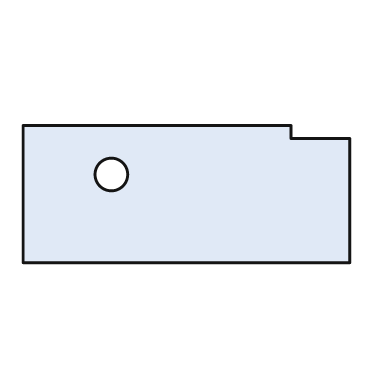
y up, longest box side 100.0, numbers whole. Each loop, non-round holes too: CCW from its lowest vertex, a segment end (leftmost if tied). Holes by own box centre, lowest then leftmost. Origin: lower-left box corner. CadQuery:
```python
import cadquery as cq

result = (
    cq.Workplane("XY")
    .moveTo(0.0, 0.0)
    .lineTo(100.0, 0.0)
    .lineTo(100.0, 38.0)
    .lineTo(82.0, 38.0)
    .lineTo(82.0, 42.0)
    .lineTo(0.0, 42.0)
    .close()
    .moveTo(27.0, 27.0)
    .circle(5.0)
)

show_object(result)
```